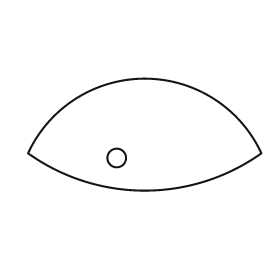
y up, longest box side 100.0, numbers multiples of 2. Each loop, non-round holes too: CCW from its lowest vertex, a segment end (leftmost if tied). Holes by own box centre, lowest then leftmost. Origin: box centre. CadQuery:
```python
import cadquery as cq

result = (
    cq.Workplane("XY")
    .moveTo(-50.0, -8.0)
    .threePointArc((0.0, -24.0), (50.0, -8.0))
    .threePointArc((0.0, 24.0), (-50.0, -8.0))
    .close()
    .moveTo(-12.0, -10.0)
    .circle(4.0)
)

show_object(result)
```